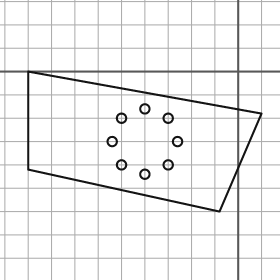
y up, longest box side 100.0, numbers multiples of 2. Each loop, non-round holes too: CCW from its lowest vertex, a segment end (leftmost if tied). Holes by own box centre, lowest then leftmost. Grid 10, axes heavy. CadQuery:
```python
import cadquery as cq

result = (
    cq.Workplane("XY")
    .moveTo(-8.0, -60.0)
    .lineTo(10.0, -18.0)
    .lineTo(-90.0, 0.0)
    .lineTo(-90.0, -42.0)
    .close()
    .moveTo(-40.0, -44.0)
    .circle(2.0)
    .moveTo(-50.0, -40.0)
    .circle(2.0)
    .moveTo(-30.0, -40.0)
    .circle(2.0)
    .moveTo(-54.0, -30.0)
    .circle(2.0)
    .moveTo(-26.0, -30.0)
    .circle(2.0)
    .moveTo(-50.0, -20.0)
    .circle(2.0)
    .moveTo(-30.0, -20.0)
    .circle(2.0)
    .moveTo(-40.0, -16.0)
    .circle(2.0)
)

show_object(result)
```